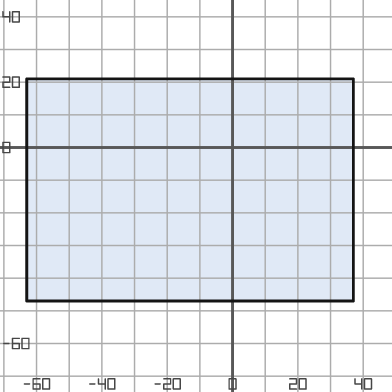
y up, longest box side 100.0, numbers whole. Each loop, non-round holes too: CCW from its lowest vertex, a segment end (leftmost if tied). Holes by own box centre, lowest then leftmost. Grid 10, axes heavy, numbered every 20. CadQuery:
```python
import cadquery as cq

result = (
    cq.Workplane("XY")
    .moveTo(-63.0, -47.0)
    .lineTo(37.0, -47.0)
    .lineTo(37.0, 21.0)
    .lineTo(-63.0, 21.0)
    .close()
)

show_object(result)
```